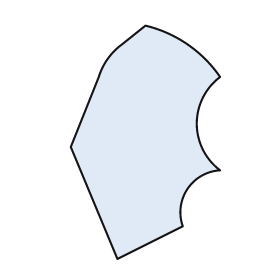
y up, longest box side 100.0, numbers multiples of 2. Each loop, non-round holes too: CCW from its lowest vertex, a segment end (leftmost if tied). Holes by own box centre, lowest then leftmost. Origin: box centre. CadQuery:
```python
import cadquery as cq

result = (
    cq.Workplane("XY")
    .moveTo(-12.0, -50.0)
    .lineTo(16.0, -36.0)
    .threePointArc((18.0, -20.0), (32.0, -12.0))
    .threePointArc((22.0, 8.0), (32.0, 28.0))
    .threePointArc((18.0, 42.0), (0.0, 50.0))
    .lineTo(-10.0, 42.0)
    .threePointArc((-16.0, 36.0), (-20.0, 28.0))
    .lineTo(-32.0, -2.0)
    .close()
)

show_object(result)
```